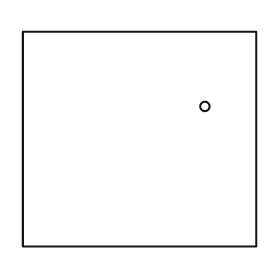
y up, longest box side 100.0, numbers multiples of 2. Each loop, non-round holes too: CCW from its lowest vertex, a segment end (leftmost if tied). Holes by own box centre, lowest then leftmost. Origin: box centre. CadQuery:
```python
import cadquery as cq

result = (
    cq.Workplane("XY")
    .moveTo(-50.0, -46.0)
    .lineTo(50.0, -46.0)
    .lineTo(50.0, 46.0)
    .lineTo(-50.0, 46.0)
    .close()
    .moveTo(28.0, 14.0)
    .circle(2.0)
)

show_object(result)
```